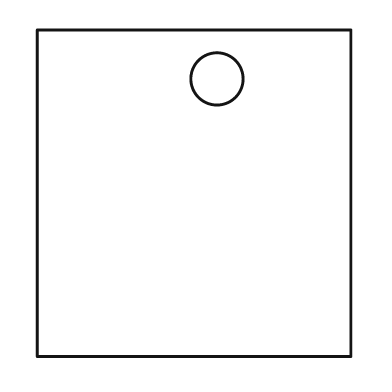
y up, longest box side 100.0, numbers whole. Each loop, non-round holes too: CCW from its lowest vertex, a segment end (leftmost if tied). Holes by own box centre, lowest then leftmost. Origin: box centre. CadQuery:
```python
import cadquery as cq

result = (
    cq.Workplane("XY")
    .moveTo(-48.0, -50.0)
    .lineTo(48.0, -50.0)
    .lineTo(48.0, 50.0)
    .lineTo(-48.0, 50.0)
    .close()
    .moveTo(7.0, 35.0)
    .circle(8.0)
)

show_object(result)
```